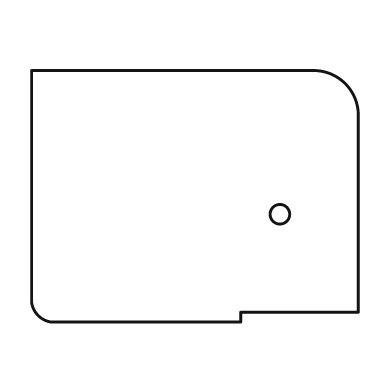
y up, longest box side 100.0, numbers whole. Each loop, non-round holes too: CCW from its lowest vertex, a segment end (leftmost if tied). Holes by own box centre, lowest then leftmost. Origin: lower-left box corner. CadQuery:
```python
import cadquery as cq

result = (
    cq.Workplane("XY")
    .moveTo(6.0, 0.0)
    .lineTo(64.0, 0.0)
    .lineTo(64.0, 3.0)
    .lineTo(100.0, 3.0)
    .lineTo(100.0, 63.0)
    .threePointArc((96.0, 73.0), (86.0, 77.0))
    .lineTo(0.0, 77.0)
    .lineTo(0.0, 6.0)
    .threePointArc((2.0, 2.0), (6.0, 0.0))
    .close()
    .moveTo(76.0, 33.0)
    .circle(3.0)
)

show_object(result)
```